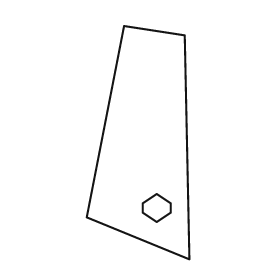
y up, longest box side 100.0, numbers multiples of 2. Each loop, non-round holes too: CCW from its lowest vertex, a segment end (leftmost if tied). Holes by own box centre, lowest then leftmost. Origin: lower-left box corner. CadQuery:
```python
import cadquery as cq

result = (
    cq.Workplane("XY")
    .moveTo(44.0, 0.0)
    .lineTo(42.0, 96.0)
    .lineTo(16.0, 100.0)
    .lineTo(0.0, 18.0)
    .close()
    .moveTo(30.0, 16.0)
    .lineTo(36.0, 20.0)
    .lineTo(36.0, 24.0)
    .lineTo(30.0, 28.0)
    .lineTo(24.0, 24.0)
    .lineTo(24.0, 20.0)
    .close()
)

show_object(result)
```